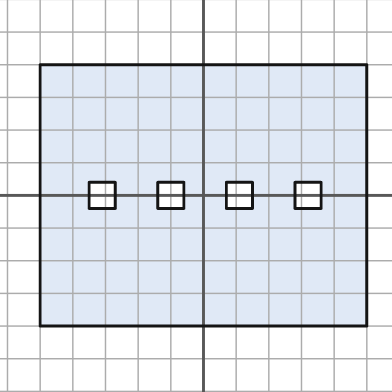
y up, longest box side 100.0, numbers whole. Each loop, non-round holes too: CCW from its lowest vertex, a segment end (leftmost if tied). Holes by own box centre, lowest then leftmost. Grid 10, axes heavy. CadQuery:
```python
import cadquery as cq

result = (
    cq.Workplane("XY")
    .moveTo(-50.0, -40.0)
    .lineTo(50.0, -40.0)
    .lineTo(50.0, 40.0)
    .lineTo(-50.0, 40.0)
    .close()
    .moveTo(-35.0, -4.0)
    .lineTo(-27.0, -4.0)
    .lineTo(-27.0, 4.0)
    .lineTo(-35.0, 4.0)
    .close()
    .moveTo(-14.0, -4.0)
    .lineTo(-6.0, -4.0)
    .lineTo(-6.0, 4.0)
    .lineTo(-14.0, 4.0)
    .close()
    .moveTo(7.0, -4.0)
    .lineTo(15.0, -4.0)
    .lineTo(15.0, 4.0)
    .lineTo(7.0, 4.0)
    .close()
    .moveTo(28.0, -4.0)
    .lineTo(36.0, -4.0)
    .lineTo(36.0, 4.0)
    .lineTo(28.0, 4.0)
    .close()
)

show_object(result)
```